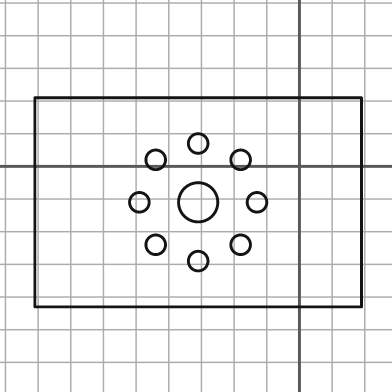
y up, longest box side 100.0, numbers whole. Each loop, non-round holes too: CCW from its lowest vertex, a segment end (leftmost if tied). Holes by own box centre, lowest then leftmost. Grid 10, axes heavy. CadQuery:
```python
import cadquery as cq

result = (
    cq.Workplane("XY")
    .moveTo(-81.0, -43.0)
    .lineTo(19.0, -43.0)
    .lineTo(19.0, 21.0)
    .lineTo(-81.0, 21.0)
    .close()
    .moveTo(-31.0, -29.0)
    .circle(3.0)
    .moveTo(-44.0, -24.0)
    .circle(3.0)
    .moveTo(-18.0, -24.0)
    .circle(3.0)
    .moveTo(-49.0, -11.0)
    .circle(3.0)
    .moveTo(-31.0, -11.0)
    .circle(6.0)
    .moveTo(-13.0, -11.0)
    .circle(3.0)
    .moveTo(-44.0, 2.0)
    .circle(3.0)
    .moveTo(-18.0, 2.0)
    .circle(3.0)
    .moveTo(-31.0, 7.0)
    .circle(3.0)
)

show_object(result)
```